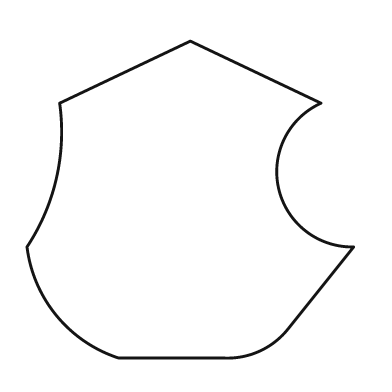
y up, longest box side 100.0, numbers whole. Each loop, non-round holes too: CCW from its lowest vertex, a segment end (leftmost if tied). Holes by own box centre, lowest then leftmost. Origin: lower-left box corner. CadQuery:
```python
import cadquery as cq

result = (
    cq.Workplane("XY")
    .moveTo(28.0, 0.0)
    .lineTo(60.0, 0.0)
    .threePointArc((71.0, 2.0), (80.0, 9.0))
    .lineTo(100.0, 34.0)
    .threePointArc((77.0, 52.0), (90.0, 78.0))
    .lineTo(50.0, 97.0)
    .lineTo(10.0, 78.0)
    .threePointArc((9.0, 55.0), (0.0, 34.0))
    .threePointArc((9.0, 13.0), (28.0, 0.0))
    .close()
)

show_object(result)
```